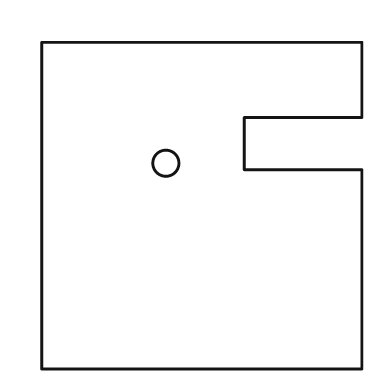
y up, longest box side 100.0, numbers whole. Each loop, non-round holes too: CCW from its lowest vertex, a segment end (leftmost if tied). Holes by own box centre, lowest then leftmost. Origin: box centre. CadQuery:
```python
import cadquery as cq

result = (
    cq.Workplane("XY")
    .moveTo(-49.0, -50.0)
    .lineTo(49.0, -50.0)
    .lineTo(49.0, 11.0)
    .lineTo(13.0, 11.0)
    .lineTo(13.0, 27.0)
    .lineTo(49.0, 27.0)
    .lineTo(49.0, 50.0)
    .lineTo(-49.0, 50.0)
    .close()
    .moveTo(-11.0, 13.0)
    .circle(4.0)
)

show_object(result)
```